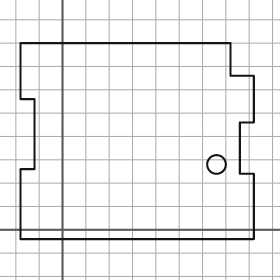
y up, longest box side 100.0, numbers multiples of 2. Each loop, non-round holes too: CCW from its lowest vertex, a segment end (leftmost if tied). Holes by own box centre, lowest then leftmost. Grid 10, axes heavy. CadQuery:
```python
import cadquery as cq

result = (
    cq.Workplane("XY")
    .moveTo(-18.0, -4.0)
    .lineTo(82.0, -4.0)
    .lineTo(82.0, 24.0)
    .lineTo(76.0, 24.0)
    .lineTo(76.0, 46.0)
    .lineTo(82.0, 46.0)
    .lineTo(82.0, 66.0)
    .lineTo(72.0, 66.0)
    .lineTo(72.0, 80.0)
    .lineTo(-18.0, 80.0)
    .lineTo(-18.0, 56.0)
    .lineTo(-12.0, 56.0)
    .lineTo(-12.0, 26.0)
    .lineTo(-18.0, 26.0)
    .close()
    .moveTo(66.0, 28.0)
    .circle(4.0)
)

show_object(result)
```